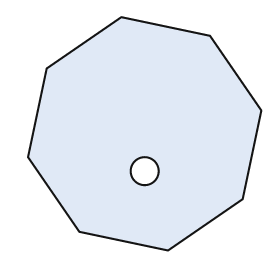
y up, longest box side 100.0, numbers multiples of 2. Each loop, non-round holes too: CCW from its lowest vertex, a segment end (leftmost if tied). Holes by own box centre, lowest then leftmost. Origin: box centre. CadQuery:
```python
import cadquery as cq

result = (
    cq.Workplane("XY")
    .moveTo(10.0, -50.0)
    .lineTo(42.0, -28.0)
    .lineTo(50.0, 10.0)
    .lineTo(28.0, 42.0)
    .lineTo(-10.0, 50.0)
    .lineTo(-42.0, 28.0)
    .lineTo(-50.0, -10.0)
    .lineTo(-28.0, -42.0)
    .close()
    .moveTo(0.0, -16.0)
    .circle(6.0)
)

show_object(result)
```